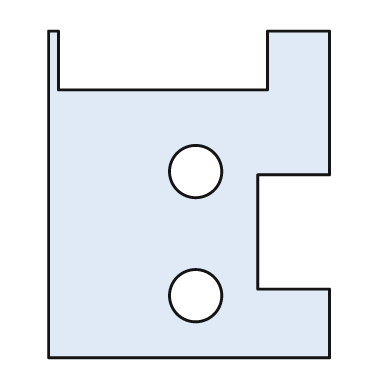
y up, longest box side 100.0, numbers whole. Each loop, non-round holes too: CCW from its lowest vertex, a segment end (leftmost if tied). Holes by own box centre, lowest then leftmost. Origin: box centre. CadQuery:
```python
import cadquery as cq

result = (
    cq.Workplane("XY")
    .moveTo(-43.0, -50.0)
    .lineTo(43.0, -50.0)
    .lineTo(43.0, -29.0)
    .lineTo(21.0, -29.0)
    .lineTo(21.0, 6.0)
    .lineTo(43.0, 6.0)
    .lineTo(43.0, 50.0)
    .lineTo(24.0, 50.0)
    .lineTo(24.0, 32.0)
    .lineTo(-40.0, 32.0)
    .lineTo(-40.0, 50.0)
    .lineTo(-43.0, 50.0)
    .close()
    .moveTo(2.0, -31.0)
    .circle(8.0)
    .moveTo(2.0, 7.0)
    .circle(8.0)
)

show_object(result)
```